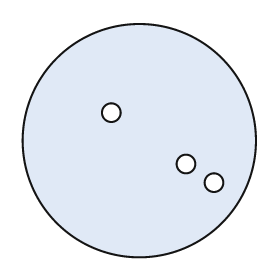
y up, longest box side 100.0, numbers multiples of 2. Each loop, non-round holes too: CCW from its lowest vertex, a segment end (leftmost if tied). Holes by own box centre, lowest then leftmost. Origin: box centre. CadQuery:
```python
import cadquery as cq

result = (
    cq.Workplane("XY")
    .moveTo(0.0, 0.0)
    .circle(50.0)
    .moveTo(32.0, -18.0)
    .circle(4.0)
    .moveTo(20.0, -10.0)
    .circle(4.0)
    .moveTo(-12.0, 12.0)
    .circle(4.0)
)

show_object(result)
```